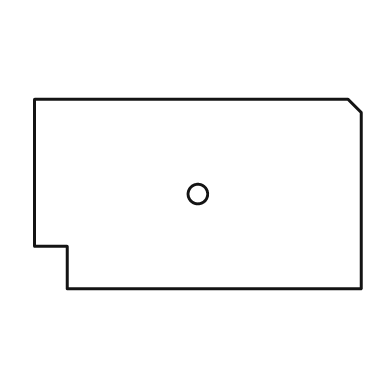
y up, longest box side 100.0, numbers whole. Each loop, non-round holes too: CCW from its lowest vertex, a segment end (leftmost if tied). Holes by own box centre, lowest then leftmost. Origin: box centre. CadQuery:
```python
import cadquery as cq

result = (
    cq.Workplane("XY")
    .moveTo(-40.0, -29.0)
    .lineTo(50.0, -29.0)
    .lineTo(50.0, 25.0)
    .lineTo(46.0, 29.0)
    .lineTo(-50.0, 29.0)
    .lineTo(-50.0, -16.0)
    .lineTo(-40.0, -16.0)
    .close()
    .moveTo(0.0, 0.0)
    .circle(3.0)
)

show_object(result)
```